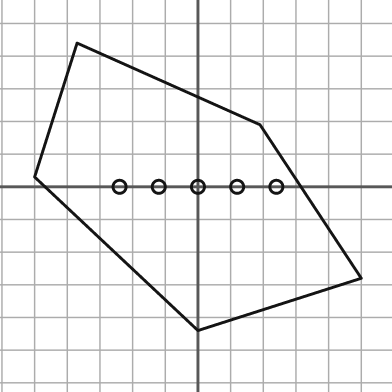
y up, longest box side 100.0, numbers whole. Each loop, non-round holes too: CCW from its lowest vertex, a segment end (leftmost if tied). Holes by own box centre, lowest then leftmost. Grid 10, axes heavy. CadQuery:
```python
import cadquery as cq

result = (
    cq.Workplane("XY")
    .moveTo(0.0, -44.0)
    .lineTo(50.0, -28.0)
    .lineTo(19.0, 19.0)
    .lineTo(-37.0, 44.0)
    .lineTo(-50.0, 3.0)
    .close()
    .moveTo(-24.0, 0.0)
    .circle(2.0)
    .moveTo(-12.0, 0.0)
    .circle(2.0)
    .moveTo(0.0, 0.0)
    .circle(2.0)
    .moveTo(12.0, 0.0)
    .circle(2.0)
    .moveTo(24.0, 0.0)
    .circle(2.0)
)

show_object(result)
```